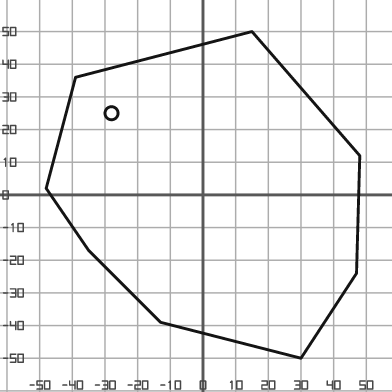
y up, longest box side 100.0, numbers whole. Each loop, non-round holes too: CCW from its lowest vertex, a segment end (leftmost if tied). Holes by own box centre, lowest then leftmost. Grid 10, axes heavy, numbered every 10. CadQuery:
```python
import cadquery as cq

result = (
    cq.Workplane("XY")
    .moveTo(30.0, -50.0)
    .lineTo(47.0, -24.0)
    .lineTo(48.0, 12.0)
    .lineTo(15.0, 50.0)
    .lineTo(-39.0, 36.0)
    .lineTo(-48.0, 2.0)
    .lineTo(-35.0, -17.0)
    .lineTo(-13.0, -39.0)
    .close()
    .moveTo(-28.0, 25.0)
    .circle(2.0)
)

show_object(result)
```